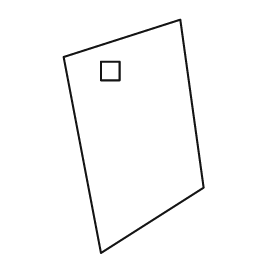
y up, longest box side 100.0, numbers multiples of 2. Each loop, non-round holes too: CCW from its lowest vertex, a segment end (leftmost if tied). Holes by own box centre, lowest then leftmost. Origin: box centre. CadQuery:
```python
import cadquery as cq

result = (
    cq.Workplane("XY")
    .moveTo(-14.0, -50.0)
    .lineTo(30.0, -22.0)
    .lineTo(20.0, 50.0)
    .lineTo(-30.0, 34.0)
    .close()
    .moveTo(-14.0, 24.0)
    .lineTo(-6.0, 24.0)
    .lineTo(-6.0, 32.0)
    .lineTo(-14.0, 32.0)
    .close()
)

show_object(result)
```